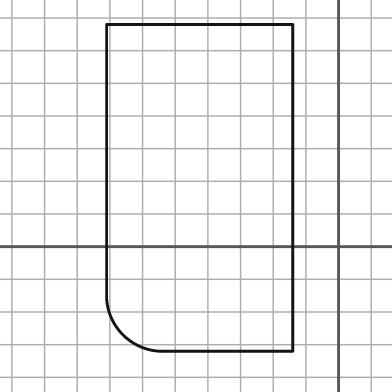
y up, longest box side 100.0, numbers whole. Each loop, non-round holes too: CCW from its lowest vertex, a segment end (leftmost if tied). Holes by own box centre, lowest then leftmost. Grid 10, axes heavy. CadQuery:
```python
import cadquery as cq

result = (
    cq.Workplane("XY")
    .moveTo(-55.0, -32.0)
    .lineTo(-14.0, -32.0)
    .lineTo(-14.0, 68.0)
    .lineTo(-71.0, 68.0)
    .lineTo(-71.0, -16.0)
    .threePointArc((-66.0, -27.0), (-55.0, -32.0))
    .close()
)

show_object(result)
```